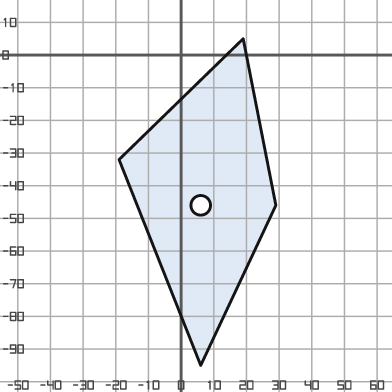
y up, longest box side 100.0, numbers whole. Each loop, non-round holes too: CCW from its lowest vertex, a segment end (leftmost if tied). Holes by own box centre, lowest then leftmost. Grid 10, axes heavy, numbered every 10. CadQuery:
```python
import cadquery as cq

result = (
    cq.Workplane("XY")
    .moveTo(6.0, -95.0)
    .lineTo(29.0, -46.0)
    .lineTo(19.0, 5.0)
    .lineTo(-19.0, -32.0)
    .close()
    .moveTo(6.0, -46.0)
    .circle(3.0)
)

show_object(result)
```